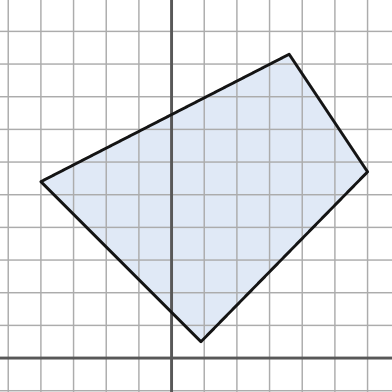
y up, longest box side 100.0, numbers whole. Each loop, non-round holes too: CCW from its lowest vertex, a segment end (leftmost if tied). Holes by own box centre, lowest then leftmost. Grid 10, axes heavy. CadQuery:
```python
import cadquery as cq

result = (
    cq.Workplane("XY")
    .moveTo(9.0, 5.0)
    .lineTo(60.0, 57.0)
    .lineTo(36.0, 93.0)
    .lineTo(-40.0, 54.0)
    .close()
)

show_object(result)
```